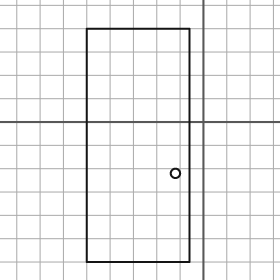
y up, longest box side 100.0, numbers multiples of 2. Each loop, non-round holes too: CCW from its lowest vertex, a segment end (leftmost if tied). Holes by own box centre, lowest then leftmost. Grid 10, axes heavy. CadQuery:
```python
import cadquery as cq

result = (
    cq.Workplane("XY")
    .moveTo(-50.0, -60.0)
    .lineTo(-6.0, -60.0)
    .lineTo(-6.0, 40.0)
    .lineTo(-50.0, 40.0)
    .close()
    .moveTo(-12.0, -22.0)
    .circle(2.0)
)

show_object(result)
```